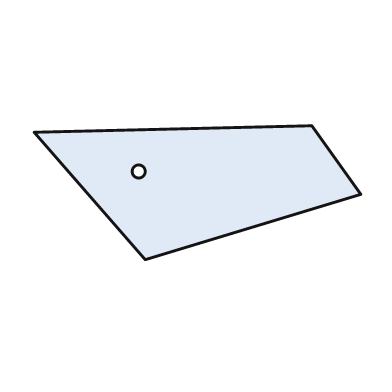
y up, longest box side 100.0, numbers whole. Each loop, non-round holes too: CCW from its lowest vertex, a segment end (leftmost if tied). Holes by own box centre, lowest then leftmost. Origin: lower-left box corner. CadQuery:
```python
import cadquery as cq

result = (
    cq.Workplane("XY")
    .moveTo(34.0, 0.0)
    .lineTo(100.0, 20.0)
    .lineTo(85.0, 41.0)
    .lineTo(0.0, 39.0)
    .close()
    .moveTo(32.0, 27.0)
    .circle(2.0)
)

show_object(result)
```